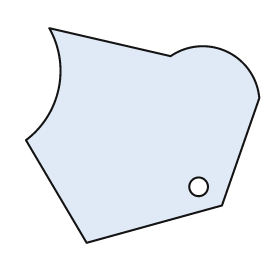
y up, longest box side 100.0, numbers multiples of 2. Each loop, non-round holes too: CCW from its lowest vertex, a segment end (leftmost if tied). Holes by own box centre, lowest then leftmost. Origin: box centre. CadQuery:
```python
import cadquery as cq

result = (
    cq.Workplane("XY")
    .moveTo(-24.0, -46.0)
    .lineTo(34.0, -30.0)
    .lineTo(50.0, 16.0)
    .threePointArc((36.0, 36.0), (12.0, 34.0))
    .lineTo(-40.0, 46.0)
    .threePointArc((-36.0, 20.0), (-50.0, -2.0))
    .close()
    .moveTo(24.0, -22.0)
    .circle(4.0)
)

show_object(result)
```